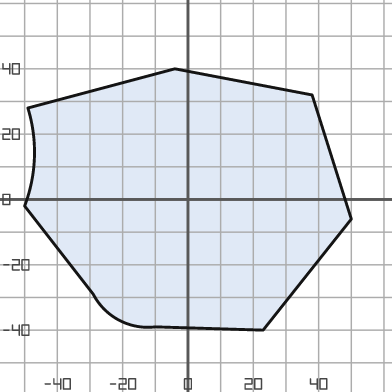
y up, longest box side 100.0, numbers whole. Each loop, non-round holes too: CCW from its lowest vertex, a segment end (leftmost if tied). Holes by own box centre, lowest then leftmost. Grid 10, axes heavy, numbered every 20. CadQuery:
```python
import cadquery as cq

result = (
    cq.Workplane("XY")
    .moveTo(23.0, -40.0)
    .lineTo(50.0, -6.0)
    .lineTo(38.0, 32.0)
    .lineTo(-4.0, 40.0)
    .lineTo(-49.0, 28.0)
    .threePointArc((-47.0, 13.0), (-50.0, -2.0))
    .lineTo(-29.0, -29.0)
    .threePointArc((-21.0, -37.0), (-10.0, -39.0))
    .close()
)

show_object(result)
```